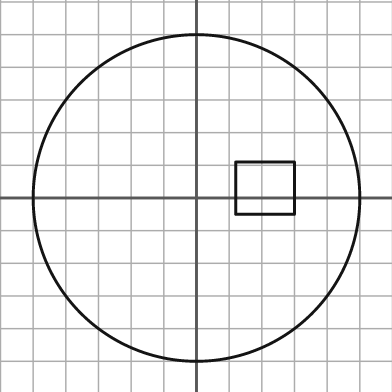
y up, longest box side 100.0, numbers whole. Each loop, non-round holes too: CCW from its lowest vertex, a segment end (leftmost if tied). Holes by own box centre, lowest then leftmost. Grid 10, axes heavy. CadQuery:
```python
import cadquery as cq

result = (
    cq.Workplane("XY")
    .moveTo(0.0, 0.0)
    .circle(50.0)
    .moveTo(12.0, -5.0)
    .lineTo(30.0, -5.0)
    .lineTo(30.0, 11.0)
    .lineTo(12.0, 11.0)
    .close()
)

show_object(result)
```